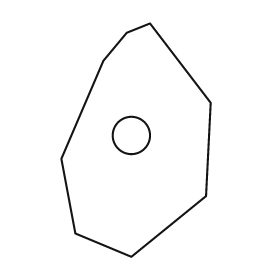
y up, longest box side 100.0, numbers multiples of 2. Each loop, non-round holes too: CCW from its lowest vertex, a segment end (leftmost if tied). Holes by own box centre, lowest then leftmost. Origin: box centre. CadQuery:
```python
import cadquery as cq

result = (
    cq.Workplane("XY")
    .moveTo(-2.0, -50.0)
    .lineTo(30.0, -24.0)
    .lineTo(32.0, 16.0)
    .lineTo(6.0, 50.0)
    .lineTo(-4.0, 46.0)
    .lineTo(-14.0, 34.0)
    .lineTo(-32.0, -8.0)
    .lineTo(-26.0, -40.0)
    .close()
    .moveTo(-2.0, 2.0)
    .circle(8.0)
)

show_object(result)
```